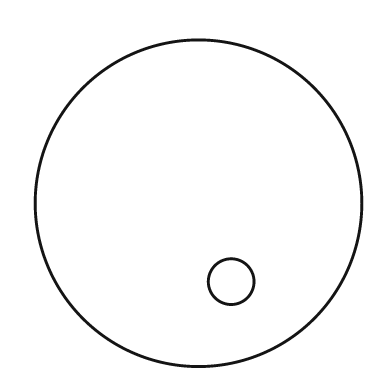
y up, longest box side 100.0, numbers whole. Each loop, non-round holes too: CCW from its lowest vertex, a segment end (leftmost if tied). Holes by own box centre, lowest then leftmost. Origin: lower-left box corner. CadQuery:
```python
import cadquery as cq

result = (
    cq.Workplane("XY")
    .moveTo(50.0, 50.0)
    .circle(50.0)
    .moveTo(60.0, 26.0)
    .circle(7.0)
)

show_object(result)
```